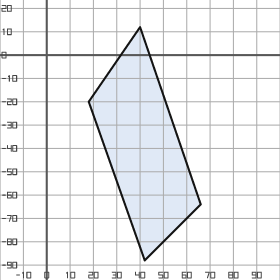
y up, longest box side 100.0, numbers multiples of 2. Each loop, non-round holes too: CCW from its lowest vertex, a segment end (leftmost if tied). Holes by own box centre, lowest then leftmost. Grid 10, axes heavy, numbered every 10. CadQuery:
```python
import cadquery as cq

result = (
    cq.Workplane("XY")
    .moveTo(42.0, -88.0)
    .lineTo(66.0, -64.0)
    .lineTo(40.0, 12.0)
    .lineTo(18.0, -20.0)
    .close()
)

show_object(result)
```